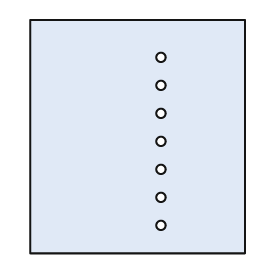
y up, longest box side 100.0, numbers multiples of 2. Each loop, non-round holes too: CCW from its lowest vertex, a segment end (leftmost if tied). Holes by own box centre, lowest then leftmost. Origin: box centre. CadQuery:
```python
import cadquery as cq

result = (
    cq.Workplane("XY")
    .moveTo(-46.0, -50.0)
    .lineTo(46.0, -50.0)
    .lineTo(46.0, 50.0)
    .lineTo(-46.0, 50.0)
    .close()
    .moveTo(10.0, -38.0)
    .circle(2.0)
    .moveTo(10.0, -26.0)
    .circle(2.0)
    .moveTo(10.0, -14.0)
    .circle(2.0)
    .moveTo(10.0, -2.0)
    .circle(2.0)
    .moveTo(10.0, 10.0)
    .circle(2.0)
    .moveTo(10.0, 22.0)
    .circle(2.0)
    .moveTo(10.0, 34.0)
    .circle(2.0)
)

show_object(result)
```